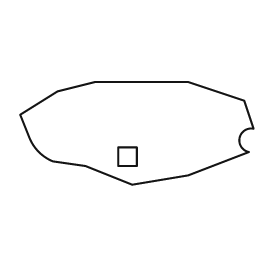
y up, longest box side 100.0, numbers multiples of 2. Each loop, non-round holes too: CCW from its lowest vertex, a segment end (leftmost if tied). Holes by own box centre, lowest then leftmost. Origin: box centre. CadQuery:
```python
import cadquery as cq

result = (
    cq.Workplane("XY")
    .moveTo(-2.0, -22.0)
    .lineTo(22.0, -18.0)
    .lineTo(48.0, -8.0)
    .threePointArc((44.0, -2.0), (50.0, 2.0))
    .lineTo(46.0, 14.0)
    .lineTo(22.0, 22.0)
    .lineTo(-18.0, 22.0)
    .lineTo(-34.0, 18.0)
    .lineTo(-50.0, 8.0)
    .lineTo(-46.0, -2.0)
    .threePointArc((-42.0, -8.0), (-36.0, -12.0))
    .lineTo(-22.0, -14.0)
    .close()
    .moveTo(-8.0, -14.0)
    .lineTo(0.0, -14.0)
    .lineTo(0.0, -6.0)
    .lineTo(-8.0, -6.0)
    .close()
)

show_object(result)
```